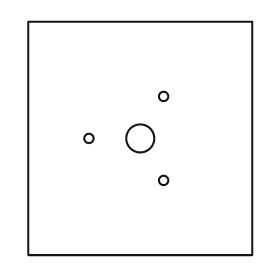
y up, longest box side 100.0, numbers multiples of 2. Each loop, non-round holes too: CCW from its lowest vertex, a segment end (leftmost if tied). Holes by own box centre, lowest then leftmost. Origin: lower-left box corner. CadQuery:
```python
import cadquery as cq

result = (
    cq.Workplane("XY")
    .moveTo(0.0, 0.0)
    .lineTo(96.0, 0.0)
    .lineTo(96.0, 100.0)
    .lineTo(0.0, 100.0)
    .close()
    .moveTo(58.0, 32.0)
    .circle(2.0)
    .moveTo(26.0, 50.0)
    .circle(2.0)
    .moveTo(48.0, 50.0)
    .circle(6.0)
    .moveTo(58.0, 68.0)
    .circle(2.0)
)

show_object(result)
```